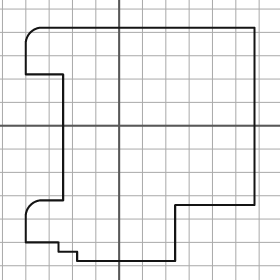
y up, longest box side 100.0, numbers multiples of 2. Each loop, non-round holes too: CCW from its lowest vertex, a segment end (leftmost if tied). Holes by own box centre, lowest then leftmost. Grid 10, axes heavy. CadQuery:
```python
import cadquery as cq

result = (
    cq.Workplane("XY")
    .moveTo(-18.0, -58.0)
    .lineTo(24.0, -58.0)
    .lineTo(24.0, -34.0)
    .lineTo(58.0, -34.0)
    .lineTo(58.0, 42.0)
    .lineTo(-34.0, 42.0)
    .threePointArc((-38.0, 40.0), (-40.0, 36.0))
    .lineTo(-40.0, 22.0)
    .lineTo(-24.0, 22.0)
    .lineTo(-24.0, -32.0)
    .lineTo(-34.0, -32.0)
    .threePointArc((-38.0, -34.0), (-40.0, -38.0))
    .lineTo(-40.0, -50.0)
    .lineTo(-26.0, -50.0)
    .lineTo(-26.0, -54.0)
    .lineTo(-18.0, -54.0)
    .close()
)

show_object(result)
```